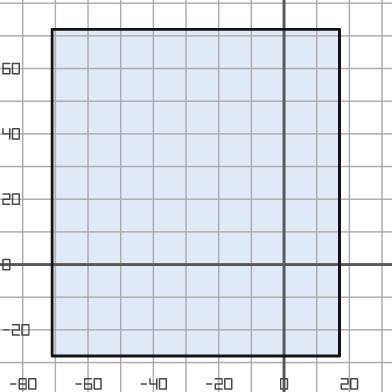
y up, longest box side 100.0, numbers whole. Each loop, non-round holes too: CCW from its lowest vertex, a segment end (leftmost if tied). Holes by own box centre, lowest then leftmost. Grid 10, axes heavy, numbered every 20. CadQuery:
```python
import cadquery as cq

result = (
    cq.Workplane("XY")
    .moveTo(-71.0, -28.0)
    .lineTo(17.0, -28.0)
    .lineTo(17.0, 72.0)
    .lineTo(-71.0, 72.0)
    .close()
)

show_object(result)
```